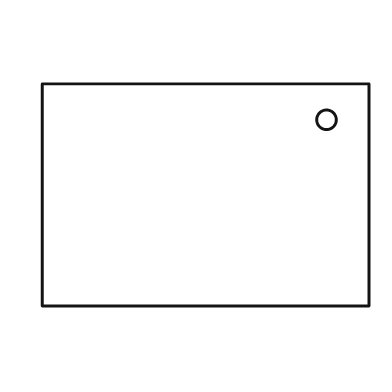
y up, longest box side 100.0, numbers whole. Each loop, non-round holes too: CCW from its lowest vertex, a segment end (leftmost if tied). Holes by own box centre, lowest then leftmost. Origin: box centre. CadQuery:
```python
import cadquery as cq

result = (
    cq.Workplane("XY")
    .moveTo(-50.0, -34.0)
    .lineTo(50.0, -34.0)
    .lineTo(50.0, 34.0)
    .lineTo(-50.0, 34.0)
    .close()
    .moveTo(37.0, 23.0)
    .circle(3.0)
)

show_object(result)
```